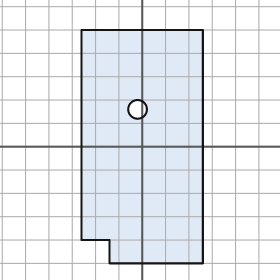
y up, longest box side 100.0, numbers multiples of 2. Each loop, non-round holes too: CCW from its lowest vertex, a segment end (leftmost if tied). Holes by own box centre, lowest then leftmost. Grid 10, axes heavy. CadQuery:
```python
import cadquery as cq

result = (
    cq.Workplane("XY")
    .moveTo(-14.0, -50.0)
    .lineTo(26.0, -50.0)
    .lineTo(26.0, 50.0)
    .lineTo(-26.0, 50.0)
    .lineTo(-26.0, -40.0)
    .lineTo(-14.0, -40.0)
    .close()
    .moveTo(-2.0, 16.0)
    .circle(4.0)
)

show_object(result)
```